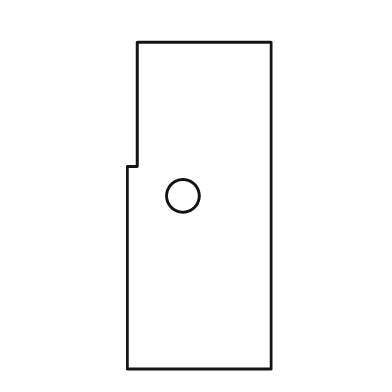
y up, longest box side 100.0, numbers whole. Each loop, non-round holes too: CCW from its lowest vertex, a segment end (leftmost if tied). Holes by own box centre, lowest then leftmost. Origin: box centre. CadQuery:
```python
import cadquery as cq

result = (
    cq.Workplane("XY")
    .moveTo(-22.0, -50.0)
    .lineTo(22.0, -50.0)
    .lineTo(22.0, 50.0)
    .lineTo(-19.0, 50.0)
    .lineTo(-19.0, 12.0)
    .lineTo(-22.0, 12.0)
    .close()
    .moveTo(-5.0, 3.0)
    .circle(5.0)
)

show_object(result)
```